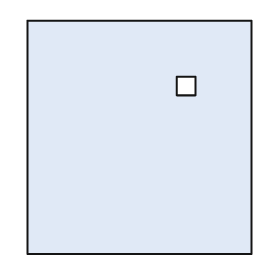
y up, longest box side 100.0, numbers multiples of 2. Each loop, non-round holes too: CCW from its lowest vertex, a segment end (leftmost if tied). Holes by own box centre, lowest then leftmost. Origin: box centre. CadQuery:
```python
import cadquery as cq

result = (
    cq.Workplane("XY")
    .moveTo(-48.0, -50.0)
    .lineTo(48.0, -50.0)
    .lineTo(48.0, 50.0)
    .lineTo(-48.0, 50.0)
    .close()
    .moveTo(16.0, 18.0)
    .lineTo(24.0, 18.0)
    .lineTo(24.0, 26.0)
    .lineTo(16.0, 26.0)
    .close()
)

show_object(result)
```